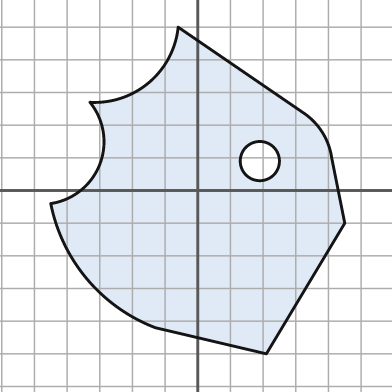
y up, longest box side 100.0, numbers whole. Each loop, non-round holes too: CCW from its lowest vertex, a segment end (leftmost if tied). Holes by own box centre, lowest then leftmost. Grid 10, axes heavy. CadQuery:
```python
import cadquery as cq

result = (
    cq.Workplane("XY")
    .moveTo(21.0, -50.0)
    .lineTo(45.0, -10.0)
    .lineTo(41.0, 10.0)
    .threePointArc((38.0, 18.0), (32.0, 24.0))
    .lineTo(-6.0, 50.0)
    .threePointArc((-15.0, 33.0), (-33.0, 27.0))
    .threePointArc((-30.0, 8.0), (-45.0, -4.0))
    .threePointArc((-34.0, -27.0), (-13.0, -42.0))
    .close()
    .moveTo(19.0, 9.0)
    .circle(6.0)
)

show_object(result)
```